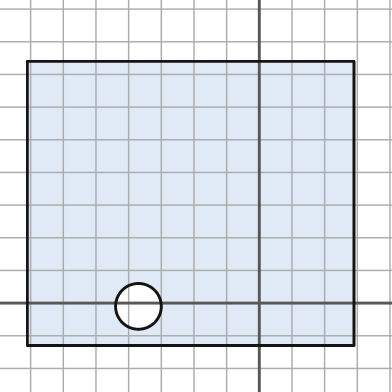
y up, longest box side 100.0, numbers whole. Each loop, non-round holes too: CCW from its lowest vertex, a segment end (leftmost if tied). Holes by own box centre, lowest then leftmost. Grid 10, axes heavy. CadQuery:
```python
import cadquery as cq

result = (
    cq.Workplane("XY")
    .moveTo(-71.0, -13.0)
    .lineTo(29.0, -13.0)
    .lineTo(29.0, 74.0)
    .lineTo(-71.0, 74.0)
    .close()
    .moveTo(-37.0, -1.0)
    .circle(7.0)
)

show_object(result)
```